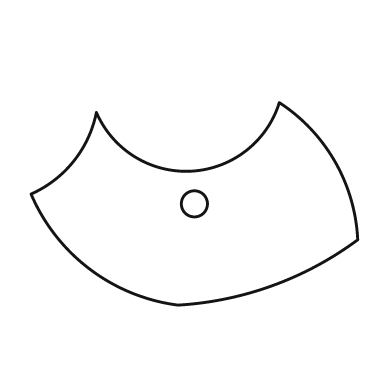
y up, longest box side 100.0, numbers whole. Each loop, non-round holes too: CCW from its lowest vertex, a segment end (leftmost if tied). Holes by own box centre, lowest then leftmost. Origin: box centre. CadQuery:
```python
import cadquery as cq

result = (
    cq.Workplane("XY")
    .moveTo(-5.0, -31.0)
    .threePointArc((24.0, -25.0), (50.0, -11.0))
    .threePointArc((43.0, 13.0), (26.0, 31.0))
    .threePointArc((-1.0, 10.0), (-30.0, 28.0))
    .threePointArc((-37.0, 13.0), (-50.0, 3.0))
    .threePointArc((-32.0, -20.0), (-5.0, -31.0))
    .close()
    .moveTo(0.0, 0.0)
    .circle(4.0)
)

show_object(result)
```